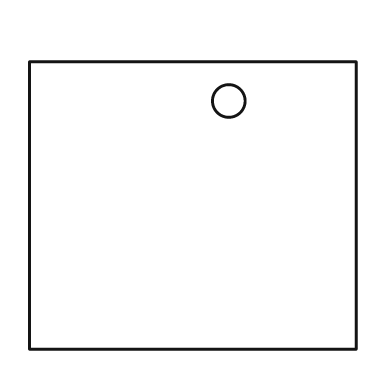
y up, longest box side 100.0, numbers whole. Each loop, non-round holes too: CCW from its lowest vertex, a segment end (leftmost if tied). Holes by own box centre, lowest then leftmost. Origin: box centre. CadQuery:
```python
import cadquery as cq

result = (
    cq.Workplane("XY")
    .moveTo(-50.0, -44.0)
    .lineTo(50.0, -44.0)
    .lineTo(50.0, 44.0)
    .lineTo(-50.0, 44.0)
    .close()
    .moveTo(11.0, 32.0)
    .circle(5.0)
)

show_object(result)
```